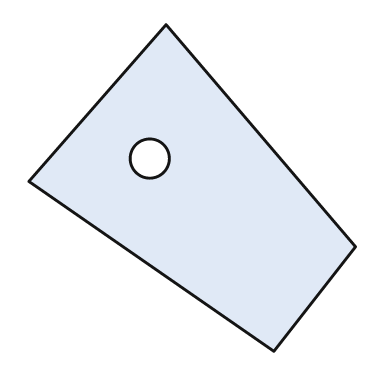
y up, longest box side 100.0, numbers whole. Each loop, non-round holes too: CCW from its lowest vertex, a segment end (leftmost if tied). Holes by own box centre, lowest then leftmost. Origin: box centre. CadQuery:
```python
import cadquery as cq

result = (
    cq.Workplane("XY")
    .moveTo(25.0, -50.0)
    .lineTo(50.0, -18.0)
    .lineTo(-8.0, 50.0)
    .lineTo(-50.0, 2.0)
    .close()
    .moveTo(-13.0, 9.0)
    .circle(6.0)
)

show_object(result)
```